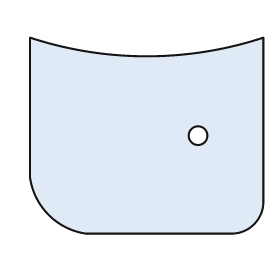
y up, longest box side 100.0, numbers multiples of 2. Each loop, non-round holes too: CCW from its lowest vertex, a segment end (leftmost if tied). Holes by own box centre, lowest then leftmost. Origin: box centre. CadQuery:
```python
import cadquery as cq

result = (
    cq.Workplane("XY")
    .moveTo(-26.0, -42.0)
    .lineTo(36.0, -42.0)
    .threePointArc((46.0, -38.0), (50.0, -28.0))
    .lineTo(50.0, 42.0)
    .threePointArc((0.0, 34.0), (-50.0, 42.0))
    .lineTo(-50.0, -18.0)
    .threePointArc((-42.0, -34.0), (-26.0, -42.0))
    .close()
    .moveTo(22.0, 0.0)
    .circle(4.0)
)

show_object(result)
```